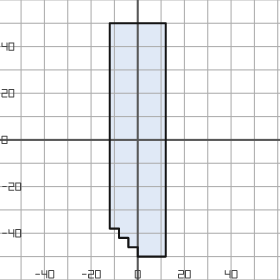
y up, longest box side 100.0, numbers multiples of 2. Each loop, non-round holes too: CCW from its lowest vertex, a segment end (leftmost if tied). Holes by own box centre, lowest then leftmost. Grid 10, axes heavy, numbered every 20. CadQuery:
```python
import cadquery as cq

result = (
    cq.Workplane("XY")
    .moveTo(0.0, -50.0)
    .lineTo(12.0, -50.0)
    .lineTo(12.0, 50.0)
    .lineTo(-12.0, 50.0)
    .lineTo(-12.0, -38.0)
    .lineTo(-8.0, -38.0)
    .lineTo(-8.0, -42.0)
    .lineTo(-4.0, -42.0)
    .lineTo(-4.0, -46.0)
    .lineTo(0.0, -46.0)
    .close()
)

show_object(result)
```